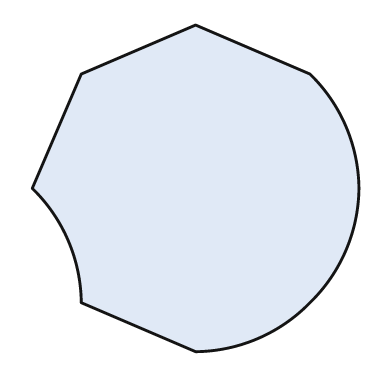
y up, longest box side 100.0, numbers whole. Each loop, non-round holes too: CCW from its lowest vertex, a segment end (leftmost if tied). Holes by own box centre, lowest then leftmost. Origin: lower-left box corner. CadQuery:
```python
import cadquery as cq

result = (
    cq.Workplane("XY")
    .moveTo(50.0, 0.0)
    .threePointArc((69.0, 4.0), (85.0, 15.0))
    .threePointArc((96.0, 31.0), (100.0, 50.0))
    .threePointArc((96.0, 69.0), (85.0, 85.0))
    .lineTo(50.0, 100.0)
    .lineTo(15.0, 85.0)
    .lineTo(0.0, 50.0)
    .threePointArc((11.0, 34.0), (15.0, 15.0))
    .close()
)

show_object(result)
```